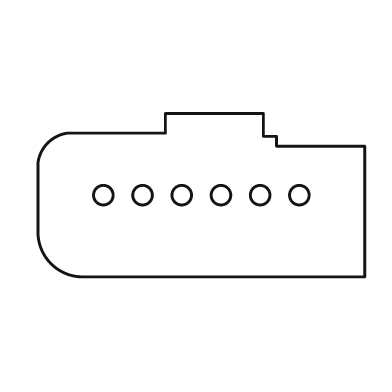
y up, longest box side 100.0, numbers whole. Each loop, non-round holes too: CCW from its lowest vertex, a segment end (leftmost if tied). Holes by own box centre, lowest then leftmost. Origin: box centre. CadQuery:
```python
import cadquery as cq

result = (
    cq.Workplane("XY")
    .moveTo(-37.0, -25.0)
    .lineTo(50.0, -25.0)
    .lineTo(50.0, 15.0)
    .lineTo(23.0, 15.0)
    .lineTo(23.0, 18.0)
    .lineTo(19.0, 18.0)
    .lineTo(19.0, 25.0)
    .lineTo(-11.0, 25.0)
    .lineTo(-11.0, 19.0)
    .lineTo(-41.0, 19.0)
    .threePointArc((-47.0, 16.0), (-50.0, 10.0))
    .lineTo(-50.0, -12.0)
    .threePointArc((-46.0, -21.0), (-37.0, -25.0))
    .close()
    .moveTo(-30.0, 0.0)
    .circle(3.0)
    .moveTo(-18.0, 0.0)
    .circle(3.0)
    .moveTo(-6.0, 0.0)
    .circle(3.0)
    .moveTo(6.0, 0.0)
    .circle(3.0)
    .moveTo(18.0, 0.0)
    .circle(3.0)
    .moveTo(30.0, 0.0)
    .circle(3.0)
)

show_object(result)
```